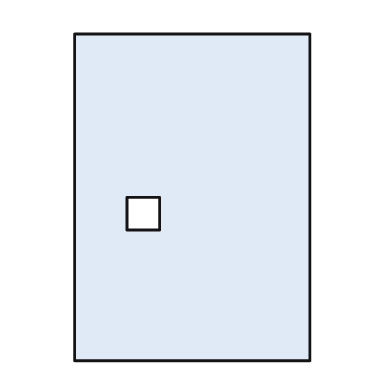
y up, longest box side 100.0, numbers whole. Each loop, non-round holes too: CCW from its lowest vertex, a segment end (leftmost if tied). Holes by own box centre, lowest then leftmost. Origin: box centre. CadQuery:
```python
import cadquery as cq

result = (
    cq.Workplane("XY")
    .moveTo(-36.0, -50.0)
    .lineTo(36.0, -50.0)
    .lineTo(36.0, 50.0)
    .lineTo(-36.0, 50.0)
    .close()
    .moveTo(-20.0, -10.0)
    .lineTo(-10.0, -10.0)
    .lineTo(-10.0, 0.0)
    .lineTo(-20.0, 0.0)
    .close()
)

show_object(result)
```